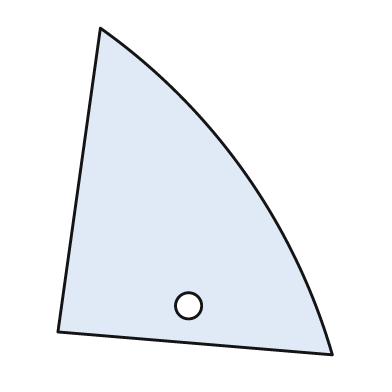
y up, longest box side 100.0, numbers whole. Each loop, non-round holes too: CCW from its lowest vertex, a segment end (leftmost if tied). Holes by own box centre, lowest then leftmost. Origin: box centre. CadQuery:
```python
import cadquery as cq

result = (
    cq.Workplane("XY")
    .moveTo(42.0, -50.0)
    .threePointArc((15.0, 6.0), (-29.0, 50.0))
    .lineTo(-42.0, -43.0)
    .close()
    .moveTo(-2.0, -35.0)
    .circle(4.0)
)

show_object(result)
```